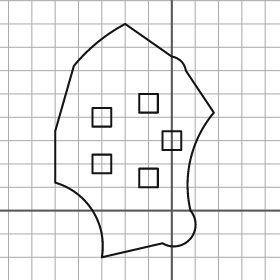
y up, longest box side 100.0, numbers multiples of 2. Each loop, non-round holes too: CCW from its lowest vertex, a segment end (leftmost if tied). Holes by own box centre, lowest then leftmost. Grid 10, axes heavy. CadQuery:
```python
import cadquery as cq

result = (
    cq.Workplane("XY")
    .moveTo(-30.0, -20.0)
    .lineTo(-4.0, -14.0)
    .threePointArc((8.0, -12.0), (8.0, 0.0))
    .threePointArc((8.0, 22.0), (18.0, 42.0))
    .lineTo(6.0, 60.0)
    .threePointArc((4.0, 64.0), (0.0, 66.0))
    .lineTo(-20.0, 80.0)
    .threePointArc((-32.0, 72.0), (-42.0, 62.0))
    .lineTo(-50.0, 34.0)
    .lineTo(-50.0, 12.0)
    .threePointArc((-34.0, 0.0), (-30.0, -20.0))
    .close()
    .moveTo(-14.0, 10.0)
    .lineTo(-6.0, 10.0)
    .lineTo(-6.0, 18.0)
    .lineTo(-14.0, 18.0)
    .close()
    .moveTo(-34.0, 16.0)
    .lineTo(-26.0, 16.0)
    .lineTo(-26.0, 24.0)
    .lineTo(-34.0, 24.0)
    .close()
    .moveTo(-4.0, 26.0)
    .lineTo(4.0, 26.0)
    .lineTo(4.0, 34.0)
    .lineTo(-4.0, 34.0)
    .close()
    .moveTo(-34.0, 36.0)
    .lineTo(-26.0, 36.0)
    .lineTo(-26.0, 44.0)
    .lineTo(-34.0, 44.0)
    .close()
    .moveTo(-14.0, 42.0)
    .lineTo(-6.0, 42.0)
    .lineTo(-6.0, 50.0)
    .lineTo(-14.0, 50.0)
    .close()
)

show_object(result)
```